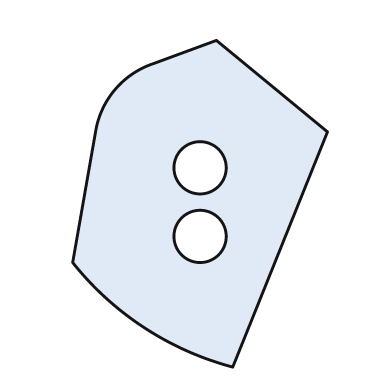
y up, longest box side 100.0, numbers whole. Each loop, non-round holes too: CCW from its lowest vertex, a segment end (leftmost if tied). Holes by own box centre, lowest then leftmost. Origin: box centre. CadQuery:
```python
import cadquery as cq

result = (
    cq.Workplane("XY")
    .moveTo(10.0, -50.0)
    .lineTo(39.0, 22.0)
    .lineTo(5.0, 50.0)
    .lineTo(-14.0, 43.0)
    .threePointArc((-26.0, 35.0), (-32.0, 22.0))
    .lineTo(-39.0, -18.0)
    .threePointArc((-17.0, -38.0), (10.0, -50.0))
    .close()
    .moveTo(0.0, -10.0)
    .circle(8.0)
    .moveTo(0.0, 11.0)
    .circle(8.0)
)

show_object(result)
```